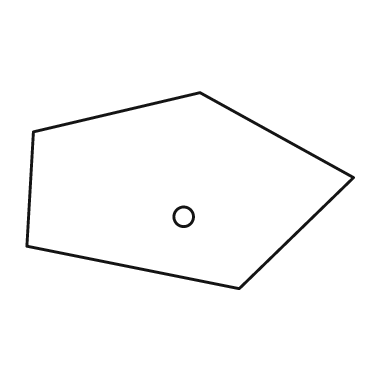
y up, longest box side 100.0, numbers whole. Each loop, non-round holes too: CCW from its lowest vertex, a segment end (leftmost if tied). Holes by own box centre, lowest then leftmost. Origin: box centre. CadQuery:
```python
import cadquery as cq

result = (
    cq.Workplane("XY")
    .moveTo(15.0, -30.0)
    .lineTo(50.0, 4.0)
    .lineTo(3.0, 30.0)
    .lineTo(-48.0, 18.0)
    .lineTo(-50.0, -17.0)
    .close()
    .moveTo(-2.0, -8.0)
    .circle(3.0)
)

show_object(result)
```